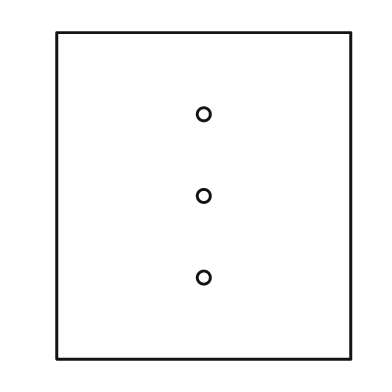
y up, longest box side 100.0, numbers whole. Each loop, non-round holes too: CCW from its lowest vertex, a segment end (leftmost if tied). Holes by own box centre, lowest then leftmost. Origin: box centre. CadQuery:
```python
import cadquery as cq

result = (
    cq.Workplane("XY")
    .moveTo(-45.0, -50.0)
    .lineTo(45.0, -50.0)
    .lineTo(45.0, 50.0)
    .lineTo(-45.0, 50.0)
    .close()
    .moveTo(0.0, -25.0)
    .circle(2.0)
    .moveTo(0.0, 0.0)
    .circle(2.0)
    .moveTo(0.0, 25.0)
    .circle(2.0)
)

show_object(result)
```